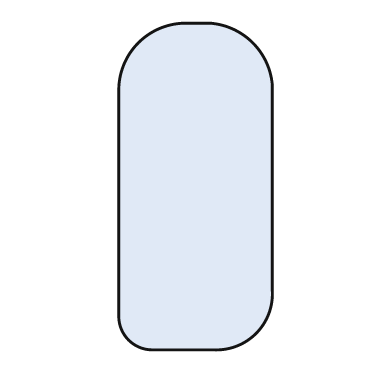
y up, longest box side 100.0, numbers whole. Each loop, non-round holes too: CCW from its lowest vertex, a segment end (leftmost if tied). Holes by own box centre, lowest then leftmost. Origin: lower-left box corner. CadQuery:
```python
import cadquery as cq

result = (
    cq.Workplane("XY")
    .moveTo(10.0, 0.0)
    .lineTo(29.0, 0.0)
    .threePointArc((42.0, 5.0), (47.0, 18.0))
    .lineTo(47.0, 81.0)
    .threePointArc((41.0, 94.0), (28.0, 100.0))
    .lineTo(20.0, 100.0)
    .threePointArc((6.0, 94.0), (0.0, 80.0))
    .lineTo(0.0, 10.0)
    .threePointArc((3.0, 3.0), (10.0, 0.0))
    .close()
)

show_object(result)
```